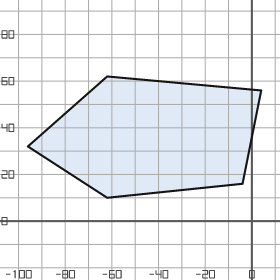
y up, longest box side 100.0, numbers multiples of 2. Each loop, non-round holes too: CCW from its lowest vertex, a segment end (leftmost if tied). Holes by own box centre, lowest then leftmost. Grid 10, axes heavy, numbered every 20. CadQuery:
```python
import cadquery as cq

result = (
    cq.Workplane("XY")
    .moveTo(-62.0, 10.0)
    .lineTo(-4.0, 16.0)
    .lineTo(4.0, 56.0)
    .lineTo(-62.0, 62.0)
    .lineTo(-96.0, 32.0)
    .close()
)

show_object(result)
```